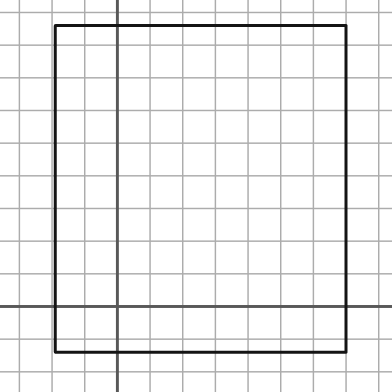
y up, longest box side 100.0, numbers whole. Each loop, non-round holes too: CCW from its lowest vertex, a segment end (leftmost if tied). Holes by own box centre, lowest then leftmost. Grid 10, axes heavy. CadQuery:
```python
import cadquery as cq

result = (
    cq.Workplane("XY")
    .moveTo(-19.0, -14.0)
    .lineTo(70.0, -14.0)
    .lineTo(70.0, 86.0)
    .lineTo(-19.0, 86.0)
    .close()
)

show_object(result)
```